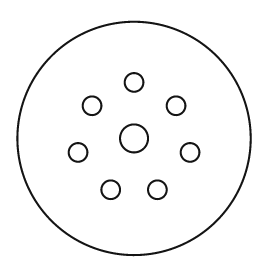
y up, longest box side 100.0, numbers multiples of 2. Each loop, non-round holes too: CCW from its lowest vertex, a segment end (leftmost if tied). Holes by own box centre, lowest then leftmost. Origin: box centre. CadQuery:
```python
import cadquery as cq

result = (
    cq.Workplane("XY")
    .moveTo(0.0, 0.0)
    .circle(50.0)
    .moveTo(-10.0, -22.0)
    .circle(4.0)
    .moveTo(10.0, -22.0)
    .circle(4.0)
    .moveTo(-24.0, -6.0)
    .circle(4.0)
    .moveTo(24.0, -6.0)
    .circle(4.0)
    .moveTo(0.0, 0.0)
    .circle(6.0)
    .moveTo(-18.0, 14.0)
    .circle(4.0)
    .moveTo(18.0, 14.0)
    .circle(4.0)
    .moveTo(0.0, 24.0)
    .circle(4.0)
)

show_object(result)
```